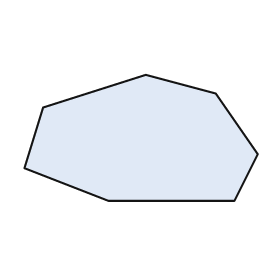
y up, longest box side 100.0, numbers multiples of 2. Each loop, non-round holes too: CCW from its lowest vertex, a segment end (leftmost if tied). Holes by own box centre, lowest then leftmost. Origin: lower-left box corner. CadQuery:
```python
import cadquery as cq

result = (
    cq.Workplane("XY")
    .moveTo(36.0, 0.0)
    .lineTo(90.0, 0.0)
    .lineTo(100.0, 20.0)
    .lineTo(82.0, 46.0)
    .lineTo(52.0, 54.0)
    .lineTo(8.0, 40.0)
    .lineTo(0.0, 14.0)
    .close()
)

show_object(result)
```